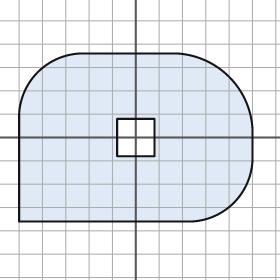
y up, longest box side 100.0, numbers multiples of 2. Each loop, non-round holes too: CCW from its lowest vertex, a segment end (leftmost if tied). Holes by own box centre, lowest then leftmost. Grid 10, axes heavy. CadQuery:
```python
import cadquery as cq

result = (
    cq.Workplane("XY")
    .moveTo(-50.0, -36.0)
    .lineTo(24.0, -36.0)
    .threePointArc((42.0, -28.0), (50.0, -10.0))
    .lineTo(50.0, 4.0)
    .threePointArc((40.0, 26.0), (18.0, 36.0))
    .lineTo(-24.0, 36.0)
    .threePointArc((-42.0, 28.0), (-50.0, 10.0))
    .close()
    .moveTo(-8.0, -8.0)
    .lineTo(8.0, -8.0)
    .lineTo(8.0, 8.0)
    .lineTo(-8.0, 8.0)
    .close()
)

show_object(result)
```